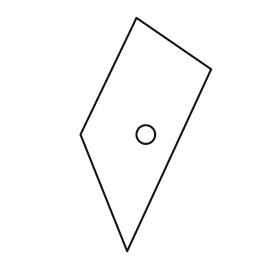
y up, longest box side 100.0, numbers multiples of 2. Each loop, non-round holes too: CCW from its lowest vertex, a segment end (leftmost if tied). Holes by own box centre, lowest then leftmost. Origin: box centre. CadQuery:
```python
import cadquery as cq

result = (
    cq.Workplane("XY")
    .moveTo(-8.0, -50.0)
    .lineTo(28.0, 28.0)
    .lineTo(-4.0, 50.0)
    .lineTo(-28.0, 0.0)
    .close()
    .moveTo(0.0, 0.0)
    .circle(4.0)
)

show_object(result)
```